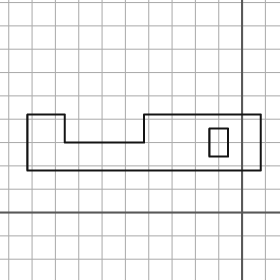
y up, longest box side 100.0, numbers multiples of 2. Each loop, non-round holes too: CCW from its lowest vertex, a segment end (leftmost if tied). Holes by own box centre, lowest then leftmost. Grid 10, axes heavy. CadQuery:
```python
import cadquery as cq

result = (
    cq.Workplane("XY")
    .moveTo(-92.0, 18.0)
    .lineTo(8.0, 18.0)
    .lineTo(8.0, 42.0)
    .lineTo(-42.0, 42.0)
    .lineTo(-42.0, 30.0)
    .lineTo(-76.0, 30.0)
    .lineTo(-76.0, 42.0)
    .lineTo(-92.0, 42.0)
    .close()
    .moveTo(-14.0, 24.0)
    .lineTo(-6.0, 24.0)
    .lineTo(-6.0, 36.0)
    .lineTo(-14.0, 36.0)
    .close()
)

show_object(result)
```